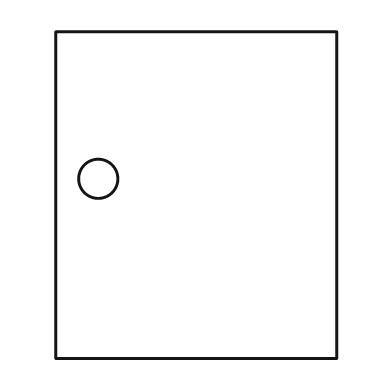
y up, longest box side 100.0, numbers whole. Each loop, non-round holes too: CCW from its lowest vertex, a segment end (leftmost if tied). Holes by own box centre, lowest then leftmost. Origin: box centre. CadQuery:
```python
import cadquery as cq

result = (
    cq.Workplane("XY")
    .moveTo(-43.0, -50.0)
    .lineTo(43.0, -50.0)
    .lineTo(43.0, 50.0)
    .lineTo(-43.0, 50.0)
    .close()
    .moveTo(-30.0, 5.0)
    .circle(6.0)
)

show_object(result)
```